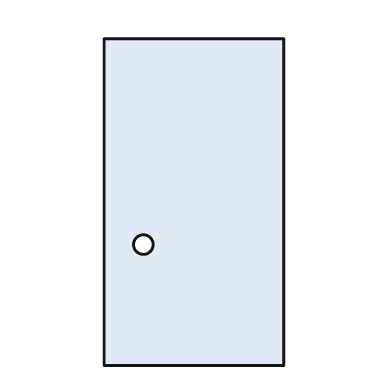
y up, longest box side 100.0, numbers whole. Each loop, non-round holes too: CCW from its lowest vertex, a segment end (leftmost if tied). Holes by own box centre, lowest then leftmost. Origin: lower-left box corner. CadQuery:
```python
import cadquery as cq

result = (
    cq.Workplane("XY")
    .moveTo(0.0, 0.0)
    .lineTo(55.0, 0.0)
    .lineTo(55.0, 100.0)
    .lineTo(0.0, 100.0)
    .close()
    .moveTo(12.0, 37.0)
    .circle(3.0)
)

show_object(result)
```